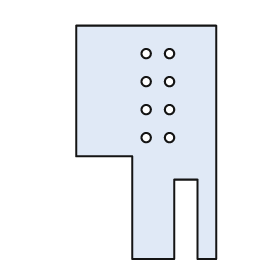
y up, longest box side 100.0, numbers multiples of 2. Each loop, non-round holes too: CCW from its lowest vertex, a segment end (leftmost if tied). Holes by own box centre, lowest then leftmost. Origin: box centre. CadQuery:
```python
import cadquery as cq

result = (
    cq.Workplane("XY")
    .moveTo(-6.0, -50.0)
    .lineTo(12.0, -50.0)
    .lineTo(12.0, -16.0)
    .lineTo(22.0, -16.0)
    .lineTo(22.0, -50.0)
    .lineTo(30.0, -50.0)
    .lineTo(30.0, 50.0)
    .lineTo(-30.0, 50.0)
    .lineTo(-30.0, -6.0)
    .lineTo(-6.0, -6.0)
    .close()
    .moveTo(0.0, 2.0)
    .circle(2.0)
    .moveTo(10.0, 2.0)
    .circle(2.0)
    .moveTo(0.0, 14.0)
    .circle(2.0)
    .moveTo(10.0, 14.0)
    .circle(2.0)
    .moveTo(0.0, 26.0)
    .circle(2.0)
    .moveTo(10.0, 26.0)
    .circle(2.0)
    .moveTo(0.0, 38.0)
    .circle(2.0)
    .moveTo(10.0, 38.0)
    .circle(2.0)
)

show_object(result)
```